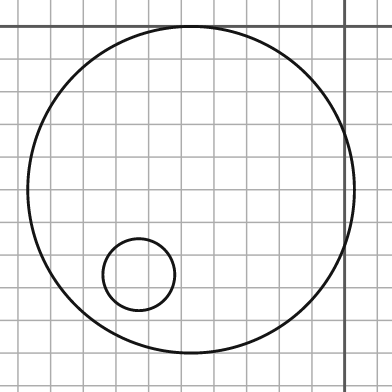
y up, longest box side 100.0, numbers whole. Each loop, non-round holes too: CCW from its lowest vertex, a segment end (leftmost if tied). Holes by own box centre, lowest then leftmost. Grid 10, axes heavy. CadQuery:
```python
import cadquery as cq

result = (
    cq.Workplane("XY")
    .moveTo(-47.0, -50.0)
    .circle(50.0)
    .moveTo(-63.0, -76.0)
    .circle(11.0)
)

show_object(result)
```